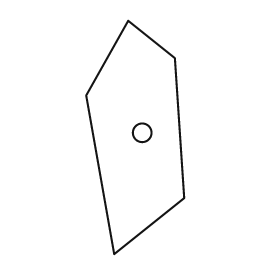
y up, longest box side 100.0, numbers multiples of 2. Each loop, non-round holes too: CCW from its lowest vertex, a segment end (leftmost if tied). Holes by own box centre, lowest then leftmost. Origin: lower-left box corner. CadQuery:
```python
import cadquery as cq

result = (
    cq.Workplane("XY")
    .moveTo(12.0, 0.0)
    .lineTo(42.0, 24.0)
    .lineTo(38.0, 84.0)
    .lineTo(18.0, 100.0)
    .lineTo(0.0, 68.0)
    .close()
    .moveTo(24.0, 52.0)
    .circle(4.0)
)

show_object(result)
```